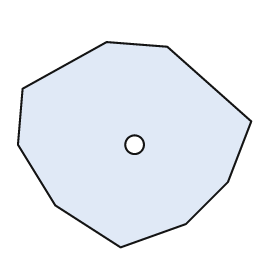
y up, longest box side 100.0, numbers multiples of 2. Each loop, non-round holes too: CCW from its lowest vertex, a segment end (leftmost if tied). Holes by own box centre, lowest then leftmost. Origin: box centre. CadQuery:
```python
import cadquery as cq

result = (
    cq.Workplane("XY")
    .moveTo(-6.0, -44.0)
    .lineTo(22.0, -34.0)
    .lineTo(40.0, -16.0)
    .lineTo(50.0, 10.0)
    .lineTo(14.0, 42.0)
    .lineTo(-12.0, 44.0)
    .lineTo(-48.0, 24.0)
    .lineTo(-50.0, 0.0)
    .lineTo(-34.0, -26.0)
    .close()
    .moveTo(0.0, 0.0)
    .circle(4.0)
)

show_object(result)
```